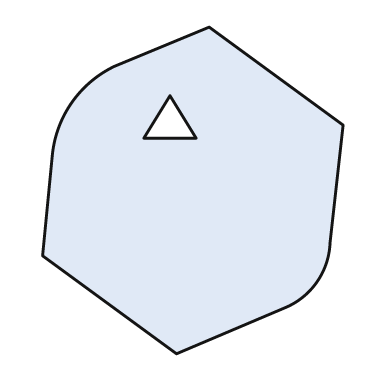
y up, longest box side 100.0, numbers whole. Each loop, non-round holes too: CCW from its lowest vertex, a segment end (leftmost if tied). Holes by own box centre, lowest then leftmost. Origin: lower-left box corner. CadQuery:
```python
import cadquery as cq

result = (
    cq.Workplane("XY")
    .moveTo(41.0, 0.0)
    .lineTo(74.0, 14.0)
    .threePointArc((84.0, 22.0), (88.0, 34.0))
    .lineTo(92.0, 70.0)
    .lineTo(51.0, 100.0)
    .lineTo(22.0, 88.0)
    .threePointArc((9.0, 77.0), (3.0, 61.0))
    .lineTo(0.0, 30.0)
    .close()
    .moveTo(31.0, 66.0)
    .lineTo(47.0, 66.0)
    .lineTo(39.0, 79.0)
    .close()
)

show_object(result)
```